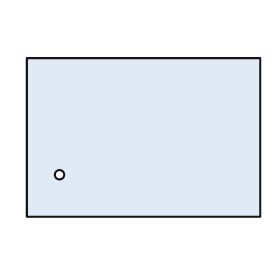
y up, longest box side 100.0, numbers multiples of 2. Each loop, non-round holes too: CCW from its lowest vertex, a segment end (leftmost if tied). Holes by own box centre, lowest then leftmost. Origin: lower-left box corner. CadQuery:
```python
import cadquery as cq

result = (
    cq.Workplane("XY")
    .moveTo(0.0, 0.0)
    .lineTo(100.0, 0.0)
    .lineTo(100.0, 68.0)
    .lineTo(0.0, 68.0)
    .close()
    .moveTo(14.0, 18.0)
    .circle(2.0)
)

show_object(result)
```